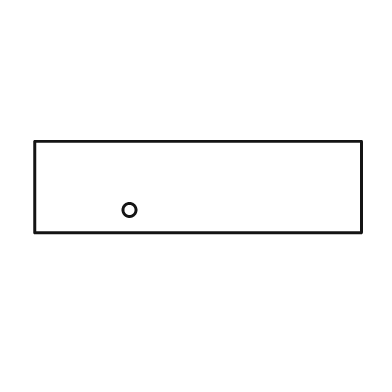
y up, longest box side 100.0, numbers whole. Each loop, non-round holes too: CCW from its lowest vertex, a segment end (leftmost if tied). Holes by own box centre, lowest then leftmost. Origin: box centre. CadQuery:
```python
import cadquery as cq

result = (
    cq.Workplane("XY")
    .moveTo(-50.0, -14.0)
    .lineTo(50.0, -14.0)
    .lineTo(50.0, 14.0)
    .lineTo(-50.0, 14.0)
    .close()
    .moveTo(-21.0, -7.0)
    .circle(2.0)
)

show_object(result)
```